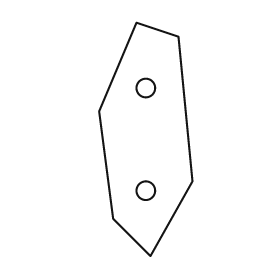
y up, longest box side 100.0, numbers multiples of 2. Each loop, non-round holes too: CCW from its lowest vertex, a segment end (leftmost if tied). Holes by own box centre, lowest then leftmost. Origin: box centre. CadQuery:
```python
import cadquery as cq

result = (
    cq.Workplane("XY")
    .moveTo(2.0, -50.0)
    .lineTo(20.0, -18.0)
    .lineTo(14.0, 44.0)
    .lineTo(-4.0, 50.0)
    .lineTo(-20.0, 12.0)
    .lineTo(-14.0, -34.0)
    .close()
    .moveTo(0.0, -22.0)
    .circle(4.0)
    .moveTo(0.0, 22.0)
    .circle(4.0)
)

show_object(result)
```